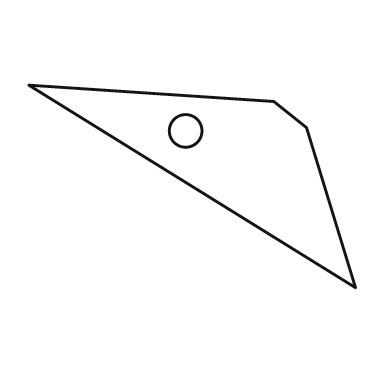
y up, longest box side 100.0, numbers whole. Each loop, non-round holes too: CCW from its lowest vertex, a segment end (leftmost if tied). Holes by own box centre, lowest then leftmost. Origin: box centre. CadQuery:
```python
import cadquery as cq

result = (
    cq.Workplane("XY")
    .moveTo(50.0, -31.0)
    .lineTo(35.0, 18.0)
    .lineTo(25.0, 26.0)
    .lineTo(-50.0, 31.0)
    .close()
    .moveTo(-2.0, 17.0)
    .circle(5.0)
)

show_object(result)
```